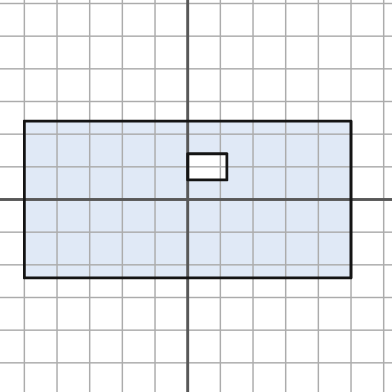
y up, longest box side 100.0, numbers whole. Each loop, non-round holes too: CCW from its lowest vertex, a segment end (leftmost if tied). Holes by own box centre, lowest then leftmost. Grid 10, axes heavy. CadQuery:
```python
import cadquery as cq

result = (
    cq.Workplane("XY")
    .moveTo(-50.0, -24.0)
    .lineTo(50.0, -24.0)
    .lineTo(50.0, 24.0)
    .lineTo(-50.0, 24.0)
    .close()
    .moveTo(0.0, 6.0)
    .lineTo(12.0, 6.0)
    .lineTo(12.0, 14.0)
    .lineTo(0.0, 14.0)
    .close()
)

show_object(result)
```